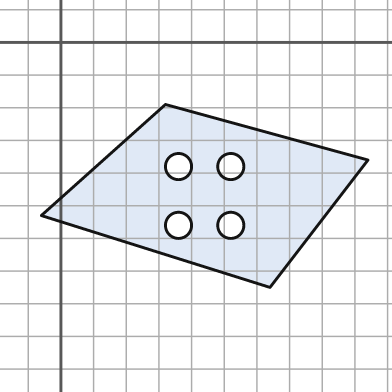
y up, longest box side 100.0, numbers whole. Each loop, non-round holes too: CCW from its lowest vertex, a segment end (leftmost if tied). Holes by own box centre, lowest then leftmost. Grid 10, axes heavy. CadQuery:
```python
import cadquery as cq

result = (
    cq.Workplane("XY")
    .moveTo(64.0, -75.0)
    .lineTo(94.0, -36.0)
    .lineTo(32.0, -19.0)
    .lineTo(-6.0, -53.0)
    .close()
    .moveTo(36.0, -56.0)
    .circle(4.0)
    .moveTo(52.0, -56.0)
    .circle(4.0)
    .moveTo(36.0, -38.0)
    .circle(4.0)
    .moveTo(52.0, -38.0)
    .circle(4.0)
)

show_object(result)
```